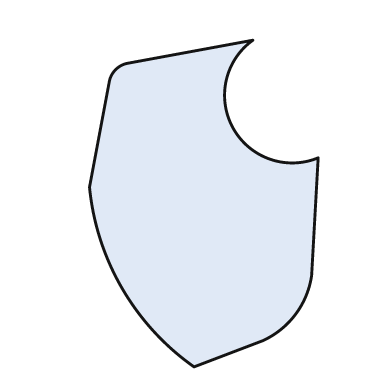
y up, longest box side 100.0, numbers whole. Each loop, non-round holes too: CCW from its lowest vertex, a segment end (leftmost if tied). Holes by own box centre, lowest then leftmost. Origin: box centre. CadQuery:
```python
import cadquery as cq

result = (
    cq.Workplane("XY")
    .moveTo(-3.0, -50.0)
    .lineTo(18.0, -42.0)
    .threePointArc((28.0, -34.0), (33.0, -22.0))
    .lineTo(35.0, 14.0)
    .threePointArc((9.0, 23.0), (15.0, 50.0))
    .lineTo(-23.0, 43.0)
    .threePointArc((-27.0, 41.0), (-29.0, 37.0))
    .lineTo(-35.0, 5.0)
    .threePointArc((-25.0, -26.0), (-3.0, -50.0))
    .close()
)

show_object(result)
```